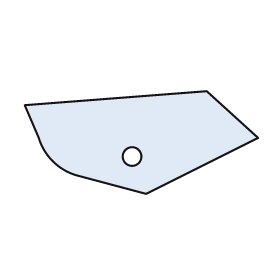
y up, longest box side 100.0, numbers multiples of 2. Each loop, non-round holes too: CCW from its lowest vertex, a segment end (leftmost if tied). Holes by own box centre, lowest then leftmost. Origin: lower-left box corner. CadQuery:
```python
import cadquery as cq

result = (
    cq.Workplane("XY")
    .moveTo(52.0, 0.0)
    .lineTo(100.0, 24.0)
    .lineTo(78.0, 44.0)
    .lineTo(0.0, 38.0)
    .lineTo(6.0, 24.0)
    .threePointArc((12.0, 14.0), (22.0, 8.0))
    .close()
    .moveTo(46.0, 16.0)
    .circle(4.0)
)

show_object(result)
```